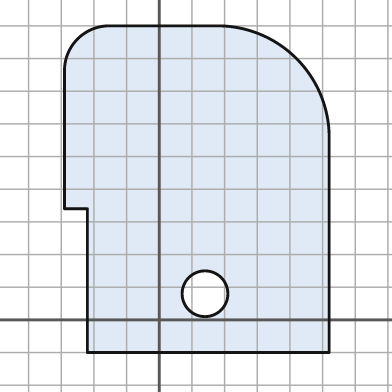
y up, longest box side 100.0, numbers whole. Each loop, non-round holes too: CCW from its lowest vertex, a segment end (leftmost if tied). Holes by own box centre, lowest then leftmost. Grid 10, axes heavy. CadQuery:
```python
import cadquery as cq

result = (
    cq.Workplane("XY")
    .moveTo(-22.0, -10.0)
    .lineTo(52.0, -10.0)
    .lineTo(52.0, 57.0)
    .threePointArc((42.0, 80.0), (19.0, 90.0))
    .lineTo(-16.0, 90.0)
    .threePointArc((-25.0, 86.0), (-29.0, 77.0))
    .lineTo(-29.0, 34.0)
    .lineTo(-22.0, 34.0)
    .close()
    .moveTo(14.0, 8.0)
    .circle(7.0)
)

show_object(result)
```